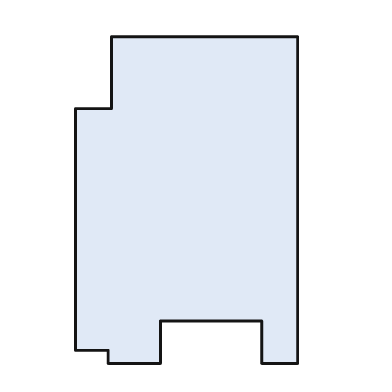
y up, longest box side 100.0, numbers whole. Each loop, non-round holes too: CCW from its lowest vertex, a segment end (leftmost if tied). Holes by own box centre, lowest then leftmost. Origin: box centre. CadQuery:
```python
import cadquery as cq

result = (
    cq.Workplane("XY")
    .moveTo(-24.0, -50.0)
    .lineTo(-8.0, -50.0)
    .lineTo(-8.0, -37.0)
    .lineTo(23.0, -37.0)
    .lineTo(23.0, -50.0)
    .lineTo(34.0, -50.0)
    .lineTo(34.0, 50.0)
    .lineTo(-23.0, 50.0)
    .lineTo(-23.0, 28.0)
    .lineTo(-34.0, 28.0)
    .lineTo(-34.0, -46.0)
    .lineTo(-24.0, -46.0)
    .close()
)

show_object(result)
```